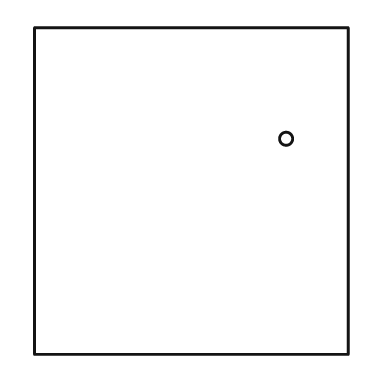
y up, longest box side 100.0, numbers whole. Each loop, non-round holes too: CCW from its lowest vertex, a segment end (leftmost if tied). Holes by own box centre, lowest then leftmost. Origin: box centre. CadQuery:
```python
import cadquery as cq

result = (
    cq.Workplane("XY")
    .moveTo(-48.0, -50.0)
    .lineTo(48.0, -50.0)
    .lineTo(48.0, 50.0)
    .lineTo(-48.0, 50.0)
    .close()
    .moveTo(29.0, 16.0)
    .circle(2.0)
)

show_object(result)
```